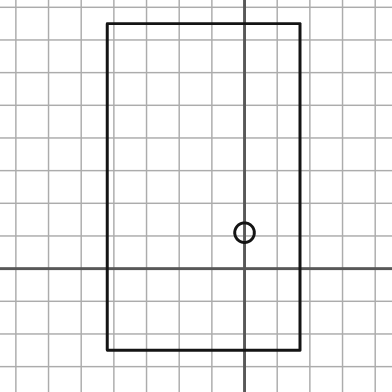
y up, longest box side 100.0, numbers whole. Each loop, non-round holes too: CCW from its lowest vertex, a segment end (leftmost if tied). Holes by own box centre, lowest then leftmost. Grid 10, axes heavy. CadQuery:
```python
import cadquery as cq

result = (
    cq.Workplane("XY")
    .moveTo(-42.0, -25.0)
    .lineTo(17.0, -25.0)
    .lineTo(17.0, 75.0)
    .lineTo(-42.0, 75.0)
    .close()
    .moveTo(0.0, 11.0)
    .circle(3.0)
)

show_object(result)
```